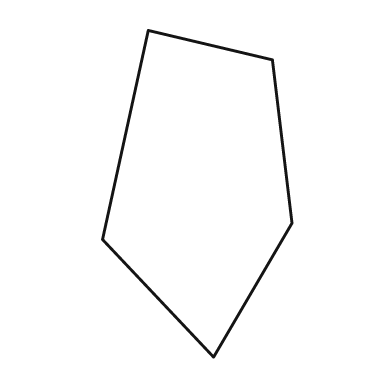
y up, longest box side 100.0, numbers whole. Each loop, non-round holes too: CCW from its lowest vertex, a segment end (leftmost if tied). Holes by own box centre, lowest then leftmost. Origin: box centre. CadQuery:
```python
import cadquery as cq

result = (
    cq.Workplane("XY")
    .moveTo(5.0, -50.0)
    .lineTo(29.0, -9.0)
    .lineTo(23.0, 41.0)
    .lineTo(-15.0, 50.0)
    .lineTo(-29.0, -14.0)
    .close()
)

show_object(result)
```